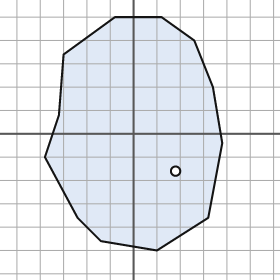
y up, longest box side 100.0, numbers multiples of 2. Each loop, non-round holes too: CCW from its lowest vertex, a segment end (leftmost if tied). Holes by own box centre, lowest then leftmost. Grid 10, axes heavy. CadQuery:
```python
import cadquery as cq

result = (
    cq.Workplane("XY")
    .moveTo(10.0, -50.0)
    .lineTo(32.0, -36.0)
    .lineTo(38.0, -4.0)
    .lineTo(34.0, 20.0)
    .lineTo(26.0, 40.0)
    .lineTo(12.0, 50.0)
    .lineTo(-8.0, 50.0)
    .lineTo(-30.0, 34.0)
    .lineTo(-32.0, 8.0)
    .lineTo(-38.0, -10.0)
    .lineTo(-24.0, -36.0)
    .lineTo(-14.0, -46.0)
    .close()
    .moveTo(18.0, -16.0)
    .circle(2.0)
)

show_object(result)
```